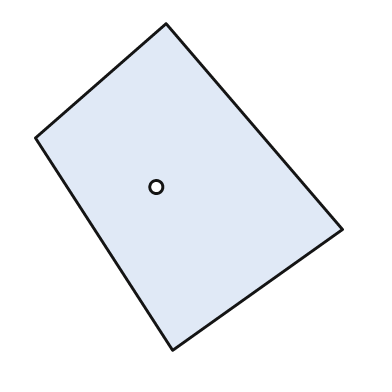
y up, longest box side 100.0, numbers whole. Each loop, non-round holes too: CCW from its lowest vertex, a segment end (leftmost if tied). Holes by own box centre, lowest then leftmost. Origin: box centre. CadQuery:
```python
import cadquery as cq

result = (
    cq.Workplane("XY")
    .moveTo(-5.0, -50.0)
    .lineTo(47.0, -13.0)
    .lineTo(-7.0, 50.0)
    .lineTo(-47.0, 15.0)
    .close()
    .moveTo(-10.0, 0.0)
    .circle(2.0)
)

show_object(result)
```